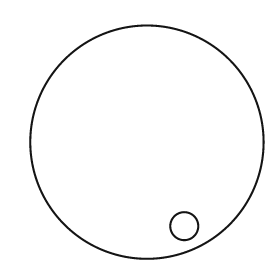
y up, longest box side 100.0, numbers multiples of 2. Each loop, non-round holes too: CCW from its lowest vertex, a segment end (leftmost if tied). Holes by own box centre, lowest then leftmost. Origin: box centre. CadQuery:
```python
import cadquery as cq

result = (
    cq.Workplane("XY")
    .moveTo(0.0, 0.0)
    .circle(50.0)
    .moveTo(16.0, -36.0)
    .circle(6.0)
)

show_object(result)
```